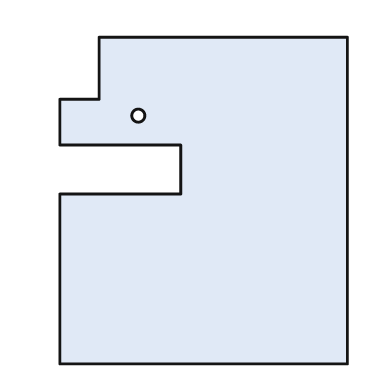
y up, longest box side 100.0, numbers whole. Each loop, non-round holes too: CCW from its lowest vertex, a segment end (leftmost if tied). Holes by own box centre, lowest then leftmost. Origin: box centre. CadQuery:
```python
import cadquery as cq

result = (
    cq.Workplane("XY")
    .moveTo(-44.0, -50.0)
    .lineTo(44.0, -50.0)
    .lineTo(44.0, 50.0)
    .lineTo(-32.0, 50.0)
    .lineTo(-32.0, 31.0)
    .lineTo(-44.0, 31.0)
    .lineTo(-44.0, 17.0)
    .lineTo(-7.0, 17.0)
    .lineTo(-7.0, 2.0)
    .lineTo(-44.0, 2.0)
    .close()
    .moveTo(-20.0, 26.0)
    .circle(2.0)
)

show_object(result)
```